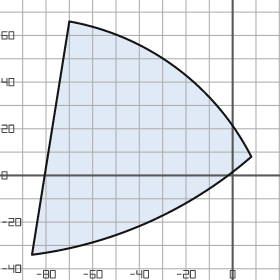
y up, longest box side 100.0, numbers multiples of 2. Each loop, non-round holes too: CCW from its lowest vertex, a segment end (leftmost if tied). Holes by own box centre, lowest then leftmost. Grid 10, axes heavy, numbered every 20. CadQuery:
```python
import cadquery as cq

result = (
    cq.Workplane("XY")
    .moveTo(-86.0, -34.0)
    .threePointArc((-36.0, -20.0), (8.0, 8.0))
    .threePointArc((-24.0, 46.0), (-70.0, 66.0))
    .close()
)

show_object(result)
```